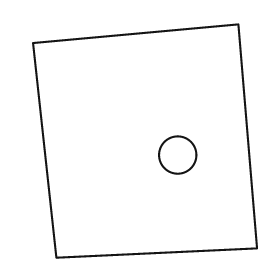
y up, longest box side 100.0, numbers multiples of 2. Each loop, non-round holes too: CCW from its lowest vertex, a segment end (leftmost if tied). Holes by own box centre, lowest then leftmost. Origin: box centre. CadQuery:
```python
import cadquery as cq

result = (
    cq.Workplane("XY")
    .moveTo(-38.0, -50.0)
    .lineTo(48.0, -46.0)
    .lineTo(40.0, 50.0)
    .lineTo(-48.0, 42.0)
    .close()
    .moveTo(14.0, -6.0)
    .circle(8.0)
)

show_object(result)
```